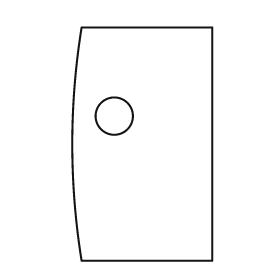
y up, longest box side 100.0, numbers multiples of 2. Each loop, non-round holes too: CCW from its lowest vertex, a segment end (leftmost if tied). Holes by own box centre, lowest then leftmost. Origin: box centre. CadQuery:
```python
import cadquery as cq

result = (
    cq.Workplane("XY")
    .moveTo(-26.0, -50.0)
    .lineTo(30.0, -50.0)
    .lineTo(30.0, 50.0)
    .lineTo(-26.0, 50.0)
    .threePointArc((-30.0, 0.0), (-26.0, -50.0))
    .close()
    .moveTo(-12.0, 12.0)
    .circle(8.0)
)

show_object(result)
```